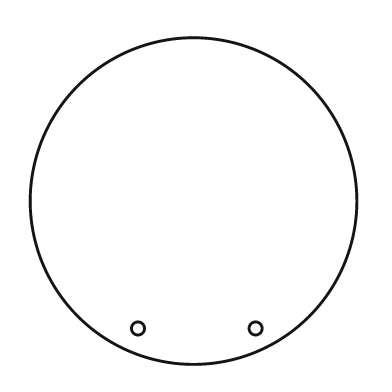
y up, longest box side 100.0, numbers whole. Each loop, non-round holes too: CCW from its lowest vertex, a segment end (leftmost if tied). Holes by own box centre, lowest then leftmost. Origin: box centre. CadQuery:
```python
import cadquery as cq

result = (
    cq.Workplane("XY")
    .moveTo(0.0, 0.0)
    .circle(50.0)
    .moveTo(-17.0, -39.0)
    .circle(2.0)
    .moveTo(19.0, -39.0)
    .circle(2.0)
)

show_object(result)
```